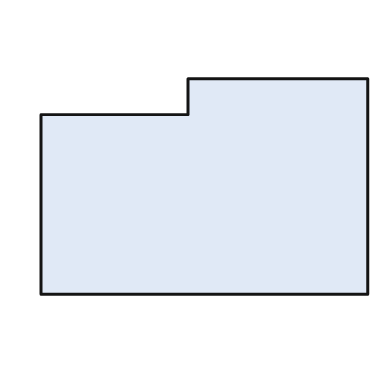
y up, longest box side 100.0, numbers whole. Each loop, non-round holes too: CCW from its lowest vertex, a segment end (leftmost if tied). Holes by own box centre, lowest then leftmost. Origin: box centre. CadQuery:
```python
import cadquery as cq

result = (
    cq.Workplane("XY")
    .moveTo(-50.0, -33.0)
    .lineTo(50.0, -33.0)
    .lineTo(50.0, 33.0)
    .lineTo(-5.0, 33.0)
    .lineTo(-5.0, 22.0)
    .lineTo(-50.0, 22.0)
    .close()
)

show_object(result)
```